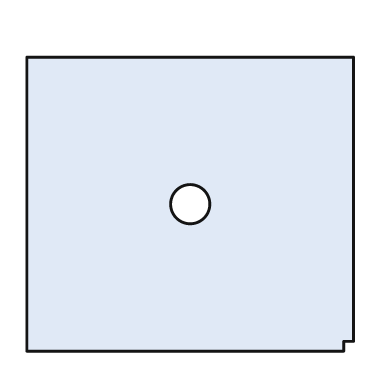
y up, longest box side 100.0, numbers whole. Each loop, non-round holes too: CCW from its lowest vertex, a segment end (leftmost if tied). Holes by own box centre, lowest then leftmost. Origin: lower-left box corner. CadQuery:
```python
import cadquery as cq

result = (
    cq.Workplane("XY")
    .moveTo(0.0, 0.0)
    .lineTo(97.0, 0.0)
    .lineTo(97.0, 3.0)
    .lineTo(100.0, 3.0)
    .lineTo(100.0, 90.0)
    .lineTo(0.0, 90.0)
    .close()
    .moveTo(50.0, 45.0)
    .circle(6.0)
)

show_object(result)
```